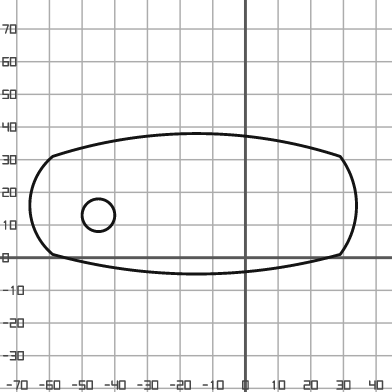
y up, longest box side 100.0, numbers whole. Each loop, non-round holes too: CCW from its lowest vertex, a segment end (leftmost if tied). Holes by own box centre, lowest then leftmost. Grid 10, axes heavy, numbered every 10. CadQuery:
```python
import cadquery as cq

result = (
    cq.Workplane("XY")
    .moveTo(-59.0, 1.0)
    .threePointArc((-15.0, -5.0), (29.0, 1.0))
    .threePointArc((34.0, 16.0), (29.0, 31.0))
    .threePointArc((-15.0, 38.0), (-59.0, 31.0))
    .threePointArc((-66.0, 16.0), (-59.0, 1.0))
    .close()
    .moveTo(-45.0, 13.0)
    .circle(5.0)
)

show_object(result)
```